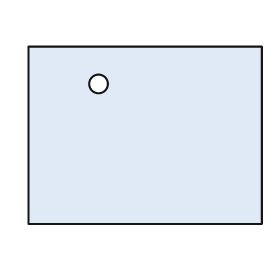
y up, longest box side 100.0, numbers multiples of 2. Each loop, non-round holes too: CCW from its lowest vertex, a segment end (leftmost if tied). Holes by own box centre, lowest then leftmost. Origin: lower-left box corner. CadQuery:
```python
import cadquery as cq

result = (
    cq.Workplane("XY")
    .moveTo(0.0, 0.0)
    .lineTo(100.0, 0.0)
    .lineTo(100.0, 76.0)
    .lineTo(0.0, 76.0)
    .close()
    .moveTo(30.0, 60.0)
    .circle(4.0)
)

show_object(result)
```